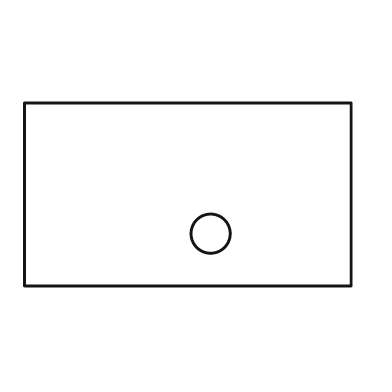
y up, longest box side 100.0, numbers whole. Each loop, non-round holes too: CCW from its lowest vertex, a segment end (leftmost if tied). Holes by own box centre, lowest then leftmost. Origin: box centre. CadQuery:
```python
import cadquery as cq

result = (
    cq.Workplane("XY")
    .moveTo(-50.0, -28.0)
    .lineTo(50.0, -28.0)
    .lineTo(50.0, 28.0)
    .lineTo(-50.0, 28.0)
    .close()
    .moveTo(7.0, -12.0)
    .circle(6.0)
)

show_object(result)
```